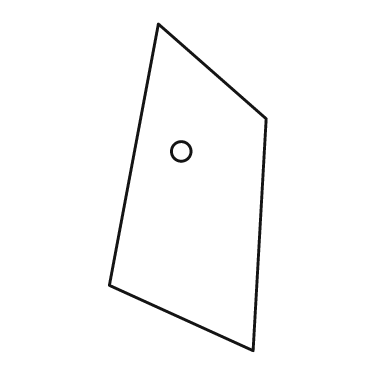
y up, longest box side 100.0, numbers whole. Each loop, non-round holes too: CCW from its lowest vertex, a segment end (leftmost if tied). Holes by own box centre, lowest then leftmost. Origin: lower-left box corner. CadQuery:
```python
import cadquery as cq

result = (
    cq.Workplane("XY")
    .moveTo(44.0, 0.0)
    .lineTo(48.0, 71.0)
    .lineTo(15.0, 100.0)
    .lineTo(0.0, 20.0)
    .close()
    .moveTo(22.0, 61.0)
    .circle(3.0)
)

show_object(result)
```